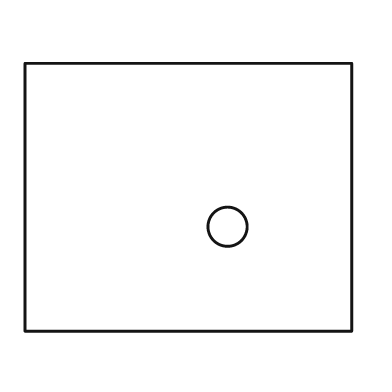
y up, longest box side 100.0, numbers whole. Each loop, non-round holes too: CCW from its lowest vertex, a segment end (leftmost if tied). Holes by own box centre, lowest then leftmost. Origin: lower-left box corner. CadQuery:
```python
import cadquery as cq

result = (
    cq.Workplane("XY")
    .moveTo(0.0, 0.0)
    .lineTo(100.0, 0.0)
    .lineTo(100.0, 82.0)
    .lineTo(0.0, 82.0)
    .close()
    .moveTo(62.0, 32.0)
    .circle(6.0)
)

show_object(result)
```